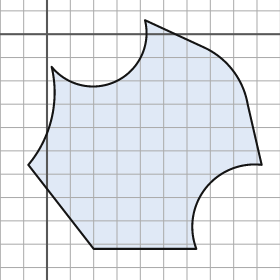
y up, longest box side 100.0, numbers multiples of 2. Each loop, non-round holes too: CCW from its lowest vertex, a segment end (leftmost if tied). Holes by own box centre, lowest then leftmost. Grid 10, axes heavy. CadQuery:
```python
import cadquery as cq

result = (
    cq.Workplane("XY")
    .moveTo(20.0, -92.0)
    .lineTo(64.0, -92.0)
    .threePointArc((68.0, -66.0), (92.0, -56.0))
    .lineTo(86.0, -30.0)
    .threePointArc((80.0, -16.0), (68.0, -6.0))
    .lineTo(42.0, 6.0)
    .threePointArc((30.0, -20.0), (2.0, -14.0))
    .threePointArc((2.0, -36.0), (-8.0, -56.0))
    .close()
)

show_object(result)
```